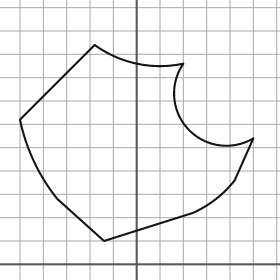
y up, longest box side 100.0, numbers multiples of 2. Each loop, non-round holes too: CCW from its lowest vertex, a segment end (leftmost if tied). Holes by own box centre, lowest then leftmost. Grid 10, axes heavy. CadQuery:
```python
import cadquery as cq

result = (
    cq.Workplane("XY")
    .moveTo(-14.0, 10.0)
    .lineTo(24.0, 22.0)
    .threePointArc((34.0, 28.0), (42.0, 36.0))
    .lineTo(50.0, 54.0)
    .threePointArc((22.0, 58.0), (20.0, 86.0))
    .threePointArc((0.0, 86.0), (-18.0, 94.0))
    .lineTo(-50.0, 62.0)
    .threePointArc((-44.0, 44.0), (-34.0, 28.0))
    .close()
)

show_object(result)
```